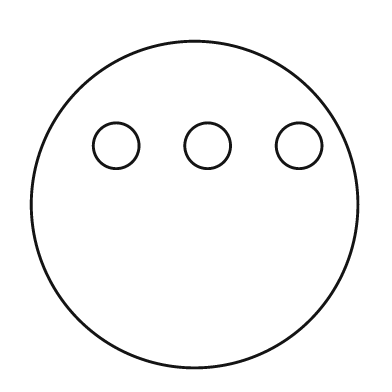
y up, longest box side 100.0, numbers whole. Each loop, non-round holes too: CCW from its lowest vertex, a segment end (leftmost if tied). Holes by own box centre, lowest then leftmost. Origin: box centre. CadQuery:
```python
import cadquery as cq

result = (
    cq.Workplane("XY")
    .moveTo(0.0, 0.0)
    .circle(50.0)
    .moveTo(-24.0, 18.0)
    .circle(7.0)
    .moveTo(4.0, 18.0)
    .circle(7.0)
    .moveTo(32.0, 18.0)
    .circle(7.0)
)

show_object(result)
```